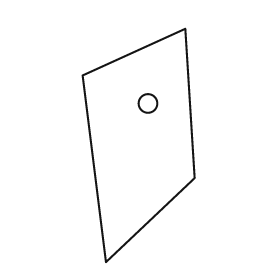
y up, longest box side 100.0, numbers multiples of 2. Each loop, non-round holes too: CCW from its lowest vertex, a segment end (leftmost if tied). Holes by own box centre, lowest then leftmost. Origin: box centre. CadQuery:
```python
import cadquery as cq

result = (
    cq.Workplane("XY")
    .moveTo(-14.0, -50.0)
    .lineTo(24.0, -14.0)
    .lineTo(20.0, 50.0)
    .lineTo(-24.0, 30.0)
    .close()
    .moveTo(4.0, 18.0)
    .circle(4.0)
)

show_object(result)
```